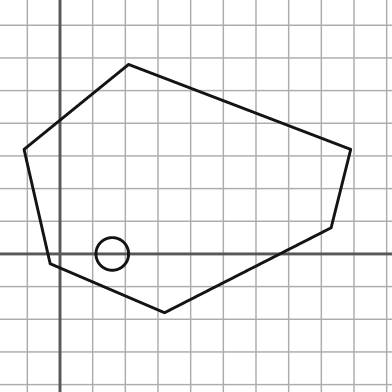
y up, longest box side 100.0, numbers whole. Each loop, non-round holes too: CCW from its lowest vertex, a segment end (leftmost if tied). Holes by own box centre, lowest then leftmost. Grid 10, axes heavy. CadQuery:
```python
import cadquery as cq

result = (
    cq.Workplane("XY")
    .moveTo(32.0, -18.0)
    .lineTo(83.0, 8.0)
    .lineTo(89.0, 32.0)
    .lineTo(21.0, 58.0)
    .lineTo(-11.0, 32.0)
    .lineTo(-3.0, -3.0)
    .close()
    .moveTo(16.0, 0.0)
    .circle(5.0)
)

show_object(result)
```